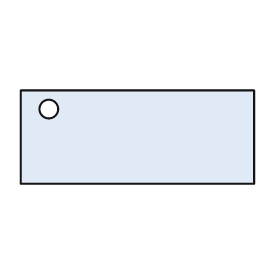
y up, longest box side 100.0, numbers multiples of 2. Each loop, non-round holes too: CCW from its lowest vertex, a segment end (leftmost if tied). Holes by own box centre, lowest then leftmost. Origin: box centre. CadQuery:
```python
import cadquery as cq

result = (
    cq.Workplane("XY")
    .moveTo(-50.0, -20.0)
    .lineTo(50.0, -20.0)
    .lineTo(50.0, 20.0)
    .lineTo(-50.0, 20.0)
    .close()
    .moveTo(-38.0, 12.0)
    .circle(4.0)
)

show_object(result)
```